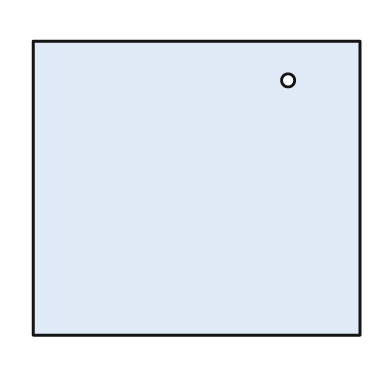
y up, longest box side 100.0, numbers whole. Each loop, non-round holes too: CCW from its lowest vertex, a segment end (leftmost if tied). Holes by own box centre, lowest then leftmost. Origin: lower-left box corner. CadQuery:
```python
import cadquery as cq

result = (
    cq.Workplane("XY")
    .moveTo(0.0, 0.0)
    .lineTo(100.0, 0.0)
    .lineTo(100.0, 90.0)
    .lineTo(0.0, 90.0)
    .close()
    .moveTo(78.0, 78.0)
    .circle(2.0)
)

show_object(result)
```